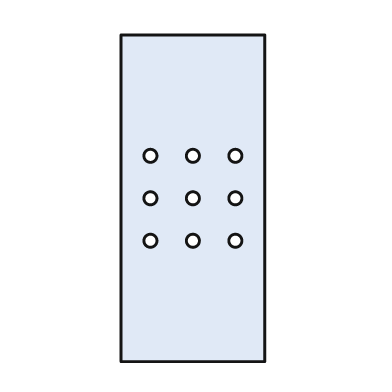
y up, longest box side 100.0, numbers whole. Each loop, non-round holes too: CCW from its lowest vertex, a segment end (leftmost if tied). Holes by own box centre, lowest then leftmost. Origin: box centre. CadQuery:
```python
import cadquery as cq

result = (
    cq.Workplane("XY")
    .moveTo(-22.0, -50.0)
    .lineTo(22.0, -50.0)
    .lineTo(22.0, 50.0)
    .lineTo(-22.0, 50.0)
    .close()
    .moveTo(-13.0, -13.0)
    .circle(2.0)
    .moveTo(0.0, -13.0)
    .circle(2.0)
    .moveTo(13.0, -13.0)
    .circle(2.0)
    .moveTo(-13.0, 0.0)
    .circle(2.0)
    .moveTo(0.0, 0.0)
    .circle(2.0)
    .moveTo(13.0, 0.0)
    .circle(2.0)
    .moveTo(-13.0, 13.0)
    .circle(2.0)
    .moveTo(0.0, 13.0)
    .circle(2.0)
    .moveTo(13.0, 13.0)
    .circle(2.0)
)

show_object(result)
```